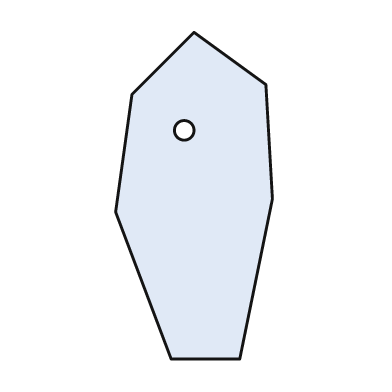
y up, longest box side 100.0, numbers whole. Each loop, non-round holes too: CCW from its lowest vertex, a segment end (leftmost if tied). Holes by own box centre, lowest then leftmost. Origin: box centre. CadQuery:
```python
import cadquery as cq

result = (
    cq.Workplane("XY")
    .moveTo(-7.0, -50.0)
    .lineTo(14.0, -50.0)
    .lineTo(24.0, -1.0)
    .lineTo(22.0, 34.0)
    .lineTo(0.0, 50.0)
    .lineTo(-19.0, 31.0)
    .lineTo(-24.0, -5.0)
    .close()
    .moveTo(-3.0, 20.0)
    .circle(3.0)
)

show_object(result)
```